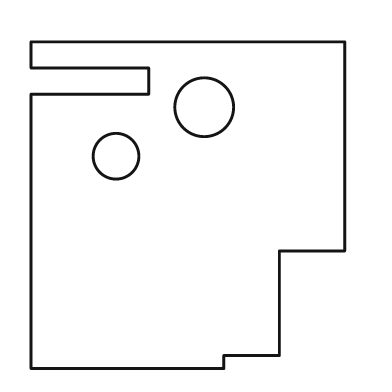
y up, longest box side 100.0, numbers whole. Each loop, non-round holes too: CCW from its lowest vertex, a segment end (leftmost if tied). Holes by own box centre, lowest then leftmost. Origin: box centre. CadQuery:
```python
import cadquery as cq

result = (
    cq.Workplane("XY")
    .moveTo(-48.0, -50.0)
    .lineTo(11.0, -50.0)
    .lineTo(11.0, -46.0)
    .lineTo(28.0, -46.0)
    .lineTo(28.0, -14.0)
    .lineTo(48.0, -14.0)
    .lineTo(48.0, 50.0)
    .lineTo(-48.0, 50.0)
    .lineTo(-48.0, 42.0)
    .lineTo(-12.0, 42.0)
    .lineTo(-12.0, 34.0)
    .lineTo(-48.0, 34.0)
    .close()
    .moveTo(-22.0, 15.0)
    .circle(7.0)
    .moveTo(5.0, 30.0)
    .circle(9.0)
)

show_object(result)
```